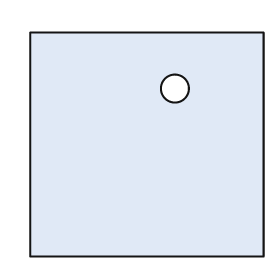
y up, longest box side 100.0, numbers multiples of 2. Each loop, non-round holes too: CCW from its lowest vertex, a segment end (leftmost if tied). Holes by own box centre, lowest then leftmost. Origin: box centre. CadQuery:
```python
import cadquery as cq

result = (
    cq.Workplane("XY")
    .moveTo(-50.0, -48.0)
    .lineTo(50.0, -48.0)
    .lineTo(50.0, 48.0)
    .lineTo(-50.0, 48.0)
    .close()
    .moveTo(12.0, 24.0)
    .circle(6.0)
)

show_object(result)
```